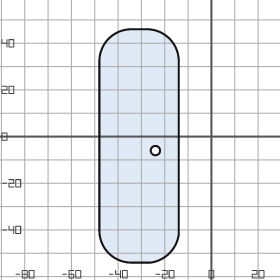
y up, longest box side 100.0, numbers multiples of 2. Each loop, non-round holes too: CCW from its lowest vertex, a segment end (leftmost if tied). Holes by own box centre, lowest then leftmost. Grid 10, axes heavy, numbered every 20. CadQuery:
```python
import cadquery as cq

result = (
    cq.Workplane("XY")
    .moveTo(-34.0, -54.0)
    .lineTo(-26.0, -54.0)
    .threePointArc((-18.0, -50.0), (-14.0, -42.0))
    .lineTo(-14.0, 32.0)
    .threePointArc((-18.0, 42.0), (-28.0, 46.0))
    .lineTo(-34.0, 46.0)
    .threePointArc((-44.0, 42.0), (-48.0, 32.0))
    .lineTo(-48.0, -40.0)
    .threePointArc((-44.0, -50.0), (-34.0, -54.0))
    .close()
    .moveTo(-24.0, -6.0)
    .circle(2.0)
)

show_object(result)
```